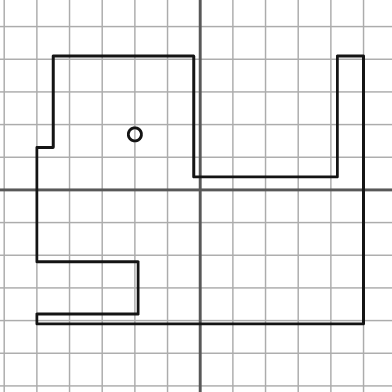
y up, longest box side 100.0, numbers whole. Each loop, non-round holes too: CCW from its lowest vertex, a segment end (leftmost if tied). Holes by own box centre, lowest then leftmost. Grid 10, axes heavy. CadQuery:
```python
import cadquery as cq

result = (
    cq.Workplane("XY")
    .moveTo(-50.0, -41.0)
    .lineTo(50.0, -41.0)
    .lineTo(50.0, 41.0)
    .lineTo(42.0, 41.0)
    .lineTo(42.0, 4.0)
    .lineTo(-2.0, 4.0)
    .lineTo(-2.0, 41.0)
    .lineTo(-45.0, 41.0)
    .lineTo(-45.0, 13.0)
    .lineTo(-50.0, 13.0)
    .lineTo(-50.0, -22.0)
    .lineTo(-19.0, -22.0)
    .lineTo(-19.0, -38.0)
    .lineTo(-50.0, -38.0)
    .close()
    .moveTo(-20.0, 17.0)
    .circle(2.0)
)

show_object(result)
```